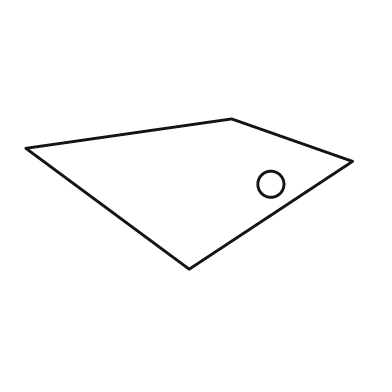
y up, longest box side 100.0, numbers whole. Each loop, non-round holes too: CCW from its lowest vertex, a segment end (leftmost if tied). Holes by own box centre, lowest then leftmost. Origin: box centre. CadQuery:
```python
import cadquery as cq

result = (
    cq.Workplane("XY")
    .moveTo(0.0, -23.0)
    .lineTo(50.0, 10.0)
    .lineTo(13.0, 23.0)
    .lineTo(-50.0, 14.0)
    .close()
    .moveTo(25.0, 3.0)
    .circle(4.0)
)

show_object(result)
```